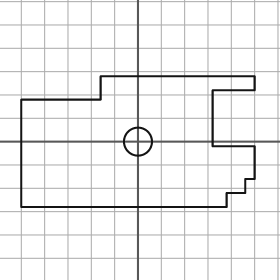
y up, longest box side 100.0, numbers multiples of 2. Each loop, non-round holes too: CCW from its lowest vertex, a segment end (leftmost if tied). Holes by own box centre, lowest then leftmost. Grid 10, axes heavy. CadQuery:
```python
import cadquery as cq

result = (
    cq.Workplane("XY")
    .moveTo(-50.0, -28.0)
    .lineTo(38.0, -28.0)
    .lineTo(38.0, -22.0)
    .lineTo(46.0, -22.0)
    .lineTo(46.0, -16.0)
    .lineTo(50.0, -16.0)
    .lineTo(50.0, -2.0)
    .lineTo(32.0, -2.0)
    .lineTo(32.0, 22.0)
    .lineTo(50.0, 22.0)
    .lineTo(50.0, 28.0)
    .lineTo(-16.0, 28.0)
    .lineTo(-16.0, 18.0)
    .lineTo(-50.0, 18.0)
    .close()
    .moveTo(0.0, 0.0)
    .circle(6.0)
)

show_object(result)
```